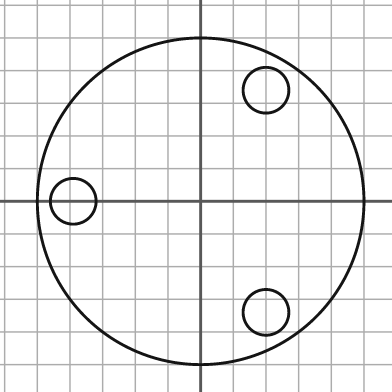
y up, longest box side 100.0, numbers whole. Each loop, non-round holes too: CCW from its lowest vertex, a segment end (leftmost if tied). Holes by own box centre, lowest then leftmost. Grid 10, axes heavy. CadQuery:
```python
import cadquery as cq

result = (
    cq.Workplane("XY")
    .moveTo(0.0, 0.0)
    .circle(50.0)
    .moveTo(20.0, -34.0)
    .circle(7.0)
    .moveTo(-39.0, 0.0)
    .circle(7.0)
    .moveTo(20.0, 34.0)
    .circle(7.0)
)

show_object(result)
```